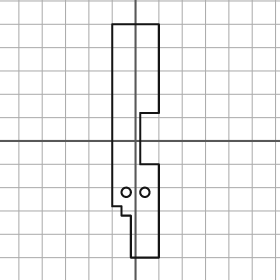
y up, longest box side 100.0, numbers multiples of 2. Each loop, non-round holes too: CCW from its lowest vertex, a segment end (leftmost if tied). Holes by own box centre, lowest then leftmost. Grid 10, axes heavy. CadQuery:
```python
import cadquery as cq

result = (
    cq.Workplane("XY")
    .moveTo(-2.0, -50.0)
    .lineTo(10.0, -50.0)
    .lineTo(10.0, -10.0)
    .lineTo(2.0, -10.0)
    .lineTo(2.0, 12.0)
    .lineTo(10.0, 12.0)
    .lineTo(10.0, 50.0)
    .lineTo(-10.0, 50.0)
    .lineTo(-10.0, -28.0)
    .lineTo(-6.0, -28.0)
    .lineTo(-6.0, -32.0)
    .lineTo(-2.0, -32.0)
    .close()
    .moveTo(-4.0, -22.0)
    .circle(2.0)
    .moveTo(4.0, -22.0)
    .circle(2.0)
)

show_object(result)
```